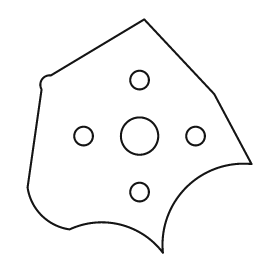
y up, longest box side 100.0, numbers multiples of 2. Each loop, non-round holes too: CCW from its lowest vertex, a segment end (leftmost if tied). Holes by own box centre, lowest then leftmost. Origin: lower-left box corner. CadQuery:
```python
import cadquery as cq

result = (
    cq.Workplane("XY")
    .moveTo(58.0, 0.0)
    .threePointArc((68.0, 28.0), (96.0, 38.0))
    .lineTo(80.0, 68.0)
    .lineTo(50.0, 100.0)
    .lineTo(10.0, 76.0)
    .threePointArc((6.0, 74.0), (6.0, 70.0))
    .lineTo(0.0, 28.0)
    .threePointArc((6.0, 16.0), (18.0, 10.0))
    .threePointArc((40.0, 12.0), (58.0, 0.0))
    .close()
    .moveTo(48.0, 26.0)
    .circle(4.0)
    .moveTo(24.0, 50.0)
    .circle(4.0)
    .moveTo(48.0, 50.0)
    .circle(8.0)
    .moveTo(72.0, 50.0)
    .circle(4.0)
    .moveTo(48.0, 74.0)
    .circle(4.0)
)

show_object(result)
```